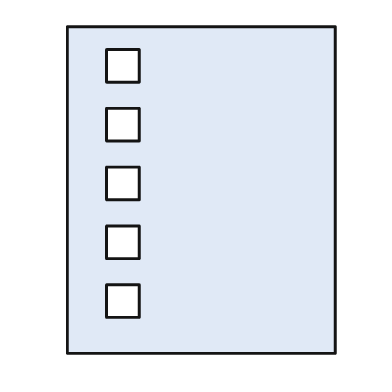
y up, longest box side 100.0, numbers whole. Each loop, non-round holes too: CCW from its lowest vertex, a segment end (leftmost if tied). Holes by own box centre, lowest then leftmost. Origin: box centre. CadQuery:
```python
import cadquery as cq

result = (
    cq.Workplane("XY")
    .moveTo(-41.0, -50.0)
    .lineTo(41.0, -50.0)
    .lineTo(41.0, 50.0)
    .lineTo(-41.0, 50.0)
    .close()
    .moveTo(-29.0, -39.0)
    .lineTo(-19.0, -39.0)
    .lineTo(-19.0, -29.0)
    .lineTo(-29.0, -29.0)
    .close()
    .moveTo(-29.0, -21.0)
    .lineTo(-19.0, -21.0)
    .lineTo(-19.0, -11.0)
    .lineTo(-29.0, -11.0)
    .close()
    .moveTo(-29.0, -3.0)
    .lineTo(-19.0, -3.0)
    .lineTo(-19.0, 7.0)
    .lineTo(-29.0, 7.0)
    .close()
    .moveTo(-29.0, 15.0)
    .lineTo(-19.0, 15.0)
    .lineTo(-19.0, 25.0)
    .lineTo(-29.0, 25.0)
    .close()
    .moveTo(-29.0, 33.0)
    .lineTo(-19.0, 33.0)
    .lineTo(-19.0, 43.0)
    .lineTo(-29.0, 43.0)
    .close()
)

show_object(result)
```